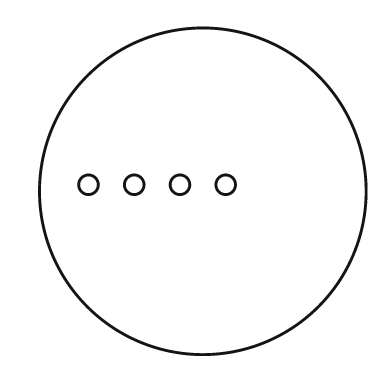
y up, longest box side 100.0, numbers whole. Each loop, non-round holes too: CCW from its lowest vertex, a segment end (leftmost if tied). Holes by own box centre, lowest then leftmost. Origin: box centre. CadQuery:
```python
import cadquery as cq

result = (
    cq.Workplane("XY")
    .moveTo(0.0, 0.0)
    .circle(50.0)
    .moveTo(-35.0, 2.0)
    .circle(3.0)
    .moveTo(-21.0, 2.0)
    .circle(3.0)
    .moveTo(-7.0, 2.0)
    .circle(3.0)
    .moveTo(7.0, 2.0)
    .circle(3.0)
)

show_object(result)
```